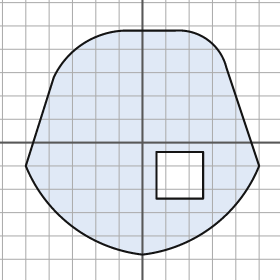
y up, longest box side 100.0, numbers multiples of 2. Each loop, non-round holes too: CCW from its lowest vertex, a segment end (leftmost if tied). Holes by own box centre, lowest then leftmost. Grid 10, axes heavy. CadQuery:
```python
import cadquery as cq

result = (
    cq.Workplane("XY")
    .moveTo(0.0, -48.0)
    .threePointArc((30.0, -36.0), (50.0, -10.0))
    .lineTo(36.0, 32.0)
    .threePointArc((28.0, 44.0), (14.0, 48.0))
    .lineTo(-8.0, 48.0)
    .threePointArc((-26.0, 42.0), (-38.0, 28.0))
    .lineTo(-50.0, -10.0)
    .threePointArc((-30.0, -36.0), (0.0, -48.0))
    .close()
    .moveTo(6.0, -24.0)
    .lineTo(26.0, -24.0)
    .lineTo(26.0, -4.0)
    .lineTo(6.0, -4.0)
    .close()
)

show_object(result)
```